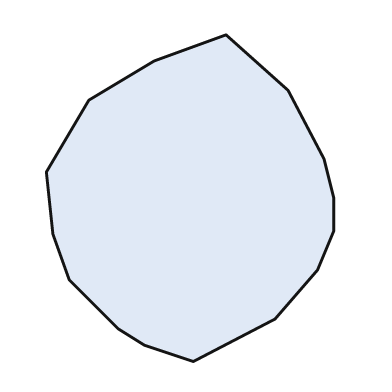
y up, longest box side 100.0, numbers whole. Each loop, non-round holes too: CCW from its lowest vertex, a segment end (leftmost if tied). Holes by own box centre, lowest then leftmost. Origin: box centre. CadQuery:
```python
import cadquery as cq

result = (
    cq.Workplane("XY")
    .moveTo(1.0, -50.0)
    .lineTo(26.0, -37.0)
    .lineTo(39.0, -22.0)
    .lineTo(44.0, -10.0)
    .lineTo(44.0, 0.0)
    .lineTo(41.0, 12.0)
    .lineTo(30.0, 33.0)
    .lineTo(11.0, 50.0)
    .lineTo(-11.0, 42.0)
    .lineTo(-31.0, 30.0)
    .lineTo(-44.0, 8.0)
    .lineTo(-42.0, -11.0)
    .lineTo(-37.0, -25.0)
    .lineTo(-22.0, -40.0)
    .lineTo(-14.0, -45.0)
    .close()
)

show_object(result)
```